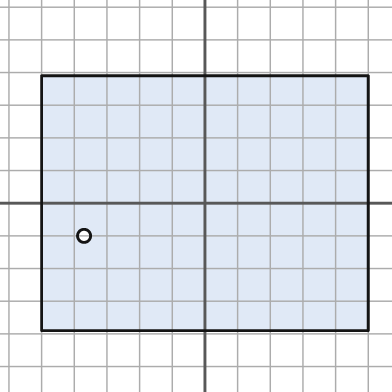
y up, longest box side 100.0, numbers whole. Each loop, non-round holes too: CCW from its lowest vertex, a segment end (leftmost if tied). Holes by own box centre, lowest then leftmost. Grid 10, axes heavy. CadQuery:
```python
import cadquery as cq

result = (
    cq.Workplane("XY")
    .moveTo(-50.0, -39.0)
    .lineTo(50.0, -39.0)
    .lineTo(50.0, 39.0)
    .lineTo(-50.0, 39.0)
    .close()
    .moveTo(-37.0, -10.0)
    .circle(2.0)
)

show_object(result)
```